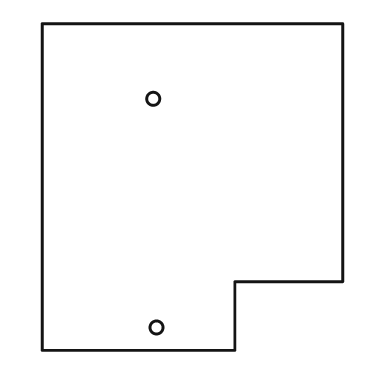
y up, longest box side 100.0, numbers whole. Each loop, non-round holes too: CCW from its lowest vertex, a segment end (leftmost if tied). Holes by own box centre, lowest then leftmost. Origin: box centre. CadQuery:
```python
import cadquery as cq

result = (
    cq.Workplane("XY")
    .moveTo(-46.0, -50.0)
    .lineTo(13.0, -50.0)
    .lineTo(13.0, -29.0)
    .lineTo(46.0, -29.0)
    .lineTo(46.0, 50.0)
    .lineTo(-46.0, 50.0)
    .close()
    .moveTo(-11.0, -43.0)
    .circle(2.0)
    .moveTo(-12.0, 27.0)
    .circle(2.0)
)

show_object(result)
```